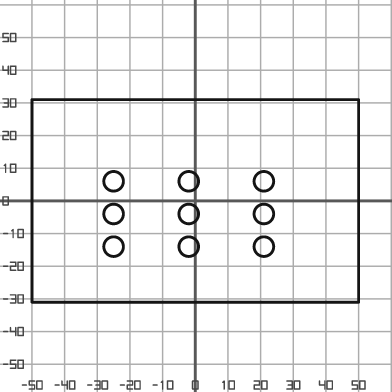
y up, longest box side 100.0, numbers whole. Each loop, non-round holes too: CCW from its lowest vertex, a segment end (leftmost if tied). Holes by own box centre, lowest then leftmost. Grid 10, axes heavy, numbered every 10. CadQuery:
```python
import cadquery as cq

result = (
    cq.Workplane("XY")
    .moveTo(-50.0, -31.0)
    .lineTo(50.0, -31.0)
    .lineTo(50.0, 31.0)
    .lineTo(-50.0, 31.0)
    .close()
    .moveTo(-25.0, -14.0)
    .circle(3.0)
    .moveTo(-2.0, -14.0)
    .circle(3.0)
    .moveTo(21.0, -14.0)
    .circle(3.0)
    .moveTo(-25.0, -4.0)
    .circle(3.0)
    .moveTo(-2.0, -4.0)
    .circle(3.0)
    .moveTo(21.0, -4.0)
    .circle(3.0)
    .moveTo(-25.0, 6.0)
    .circle(3.0)
    .moveTo(-2.0, 6.0)
    .circle(3.0)
    .moveTo(21.0, 6.0)
    .circle(3.0)
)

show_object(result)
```